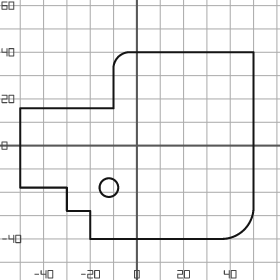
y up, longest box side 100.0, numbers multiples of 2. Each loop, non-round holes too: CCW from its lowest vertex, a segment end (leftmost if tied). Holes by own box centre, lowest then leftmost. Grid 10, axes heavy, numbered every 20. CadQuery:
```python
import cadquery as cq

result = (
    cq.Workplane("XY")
    .moveTo(-20.0, -40.0)
    .lineTo(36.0, -40.0)
    .threePointArc((46.0, -36.0), (50.0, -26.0))
    .lineTo(50.0, 40.0)
    .lineTo(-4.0, 40.0)
    .threePointArc((-8.0, 38.0), (-10.0, 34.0))
    .lineTo(-10.0, 16.0)
    .lineTo(-50.0, 16.0)
    .lineTo(-50.0, -18.0)
    .lineTo(-30.0, -18.0)
    .lineTo(-30.0, -28.0)
    .lineTo(-20.0, -28.0)
    .close()
    .moveTo(-12.0, -18.0)
    .circle(4.0)
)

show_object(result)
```